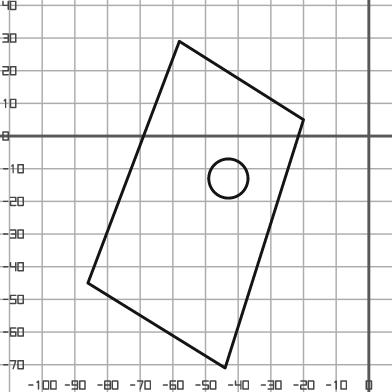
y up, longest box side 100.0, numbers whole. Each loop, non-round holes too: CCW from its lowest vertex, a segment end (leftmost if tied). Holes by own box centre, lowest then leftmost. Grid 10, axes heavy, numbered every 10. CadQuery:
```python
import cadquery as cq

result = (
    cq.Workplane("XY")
    .moveTo(-44.0, -71.0)
    .lineTo(-20.0, 5.0)
    .lineTo(-58.0, 29.0)
    .lineTo(-86.0, -45.0)
    .close()
    .moveTo(-43.0, -13.0)
    .circle(6.0)
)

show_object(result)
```